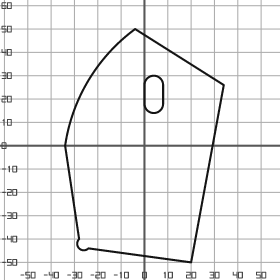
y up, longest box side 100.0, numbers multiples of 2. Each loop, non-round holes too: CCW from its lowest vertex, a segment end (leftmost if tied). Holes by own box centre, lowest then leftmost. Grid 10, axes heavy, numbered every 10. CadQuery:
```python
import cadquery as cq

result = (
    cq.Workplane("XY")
    .moveTo(20.0, -50.0)
    .lineTo(34.0, 26.0)
    .lineTo(-4.0, 50.0)
    .threePointArc((-24.0, 28.0), (-34.0, 0.0))
    .lineTo(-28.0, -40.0)
    .threePointArc((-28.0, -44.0), (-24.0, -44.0))
    .close()
    .moveTo(0.0, 18.0)
    .threePointArc((4.0, 14.0), (8.0, 18.0))
    .lineTo(8.0, 26.0)
    .threePointArc((4.0, 30.0), (0.0, 26.0))
    .close()
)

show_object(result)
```